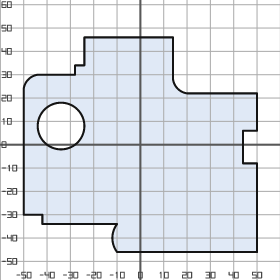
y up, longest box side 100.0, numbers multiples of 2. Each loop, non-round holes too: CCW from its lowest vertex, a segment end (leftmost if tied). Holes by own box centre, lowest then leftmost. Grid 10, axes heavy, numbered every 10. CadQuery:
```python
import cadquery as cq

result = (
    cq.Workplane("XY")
    .moveTo(-10.0, -46.0)
    .lineTo(50.0, -46.0)
    .lineTo(50.0, -8.0)
    .lineTo(44.0, -8.0)
    .lineTo(44.0, 6.0)
    .lineTo(50.0, 6.0)
    .lineTo(50.0, 22.0)
    .lineTo(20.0, 22.0)
    .threePointArc((16.0, 24.0), (14.0, 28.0))
    .lineTo(14.0, 46.0)
    .lineTo(-24.0, 46.0)
    .lineTo(-24.0, 34.0)
    .lineTo(-28.0, 34.0)
    .lineTo(-28.0, 30.0)
    .lineTo(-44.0, 30.0)
    .threePointArc((-48.0, 28.0), (-50.0, 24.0))
    .lineTo(-50.0, -30.0)
    .lineTo(-42.0, -30.0)
    .lineTo(-42.0, -34.0)
    .lineTo(-10.0, -34.0)
    .threePointArc((-12.0, -40.0), (-10.0, -46.0))
    .close()
    .moveTo(-34.0, 8.0)
    .circle(10.0)
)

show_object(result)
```